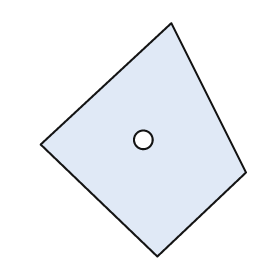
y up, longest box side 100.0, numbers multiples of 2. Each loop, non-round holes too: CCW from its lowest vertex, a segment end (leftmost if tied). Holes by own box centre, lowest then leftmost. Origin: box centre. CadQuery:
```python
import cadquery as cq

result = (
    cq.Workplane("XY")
    .moveTo(6.0, -50.0)
    .lineTo(44.0, -14.0)
    .lineTo(12.0, 50.0)
    .lineTo(-44.0, -2.0)
    .close()
    .moveTo(0.0, 0.0)
    .circle(4.0)
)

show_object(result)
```